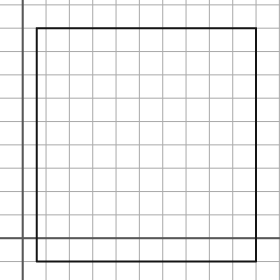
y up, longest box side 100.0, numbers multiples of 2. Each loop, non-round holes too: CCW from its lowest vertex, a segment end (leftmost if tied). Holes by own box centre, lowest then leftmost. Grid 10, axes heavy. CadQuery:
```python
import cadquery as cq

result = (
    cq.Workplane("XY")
    .moveTo(6.0, -10.0)
    .lineTo(100.0, -10.0)
    .lineTo(100.0, 90.0)
    .lineTo(6.0, 90.0)
    .close()
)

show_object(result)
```